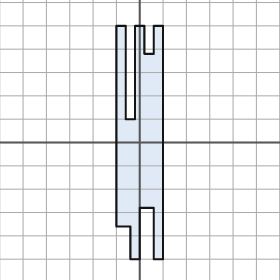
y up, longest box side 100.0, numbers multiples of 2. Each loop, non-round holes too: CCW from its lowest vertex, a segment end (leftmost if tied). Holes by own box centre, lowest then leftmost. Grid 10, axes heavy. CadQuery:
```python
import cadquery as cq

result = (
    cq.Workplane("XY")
    .moveTo(-4.0, -50.0)
    .lineTo(0.0, -50.0)
    .lineTo(0.0, -28.0)
    .lineTo(6.0, -28.0)
    .lineTo(6.0, -50.0)
    .lineTo(10.0, -50.0)
    .lineTo(10.0, 50.0)
    .lineTo(6.0, 50.0)
    .lineTo(6.0, 38.0)
    .lineTo(2.0, 38.0)
    .lineTo(2.0, 50.0)
    .lineTo(-2.0, 50.0)
    .lineTo(-2.0, 10.0)
    .lineTo(-6.0, 10.0)
    .lineTo(-6.0, 50.0)
    .lineTo(-10.0, 50.0)
    .lineTo(-10.0, -36.0)
    .lineTo(-4.0, -36.0)
    .close()
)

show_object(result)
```